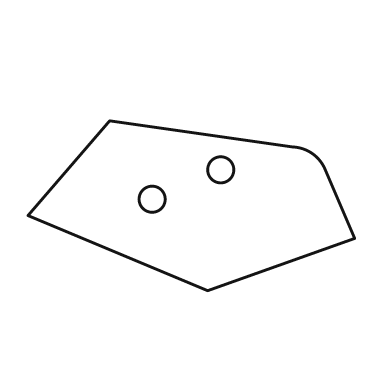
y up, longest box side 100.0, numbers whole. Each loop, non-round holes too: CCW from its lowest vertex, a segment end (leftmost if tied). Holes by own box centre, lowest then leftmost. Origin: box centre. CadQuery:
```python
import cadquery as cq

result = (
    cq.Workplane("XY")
    .moveTo(5.0, -26.0)
    .lineTo(50.0, -10.0)
    .lineTo(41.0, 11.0)
    .threePointArc((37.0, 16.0), (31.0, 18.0))
    .lineTo(-25.0, 26.0)
    .lineTo(-50.0, -3.0)
    .close()
    .moveTo(-12.0, 2.0)
    .circle(4.0)
    .moveTo(9.0, 11.0)
    .circle(4.0)
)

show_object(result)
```